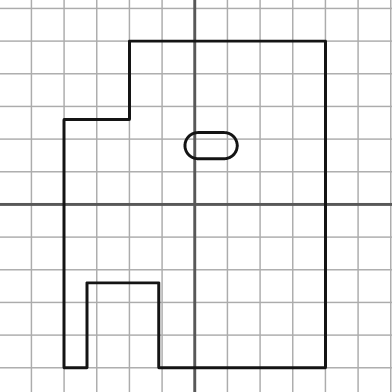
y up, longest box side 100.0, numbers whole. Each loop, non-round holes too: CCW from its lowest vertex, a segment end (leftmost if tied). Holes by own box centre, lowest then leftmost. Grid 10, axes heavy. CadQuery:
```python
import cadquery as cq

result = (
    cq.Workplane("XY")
    .moveTo(-40.0, -50.0)
    .lineTo(-33.0, -50.0)
    .lineTo(-33.0, -24.0)
    .lineTo(-11.0, -24.0)
    .lineTo(-11.0, -50.0)
    .lineTo(40.0, -50.0)
    .lineTo(40.0, 50.0)
    .lineTo(-20.0, 50.0)
    .lineTo(-20.0, 26.0)
    .lineTo(-40.0, 26.0)
    .close()
    .moveTo(1.0, 14.0)
    .lineTo(9.0, 14.0)
    .threePointArc((13.0, 18.0), (9.0, 22.0))
    .lineTo(1.0, 22.0)
    .threePointArc((-3.0, 18.0), (1.0, 14.0))
    .close()
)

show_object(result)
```